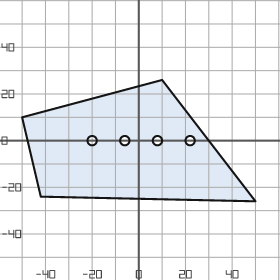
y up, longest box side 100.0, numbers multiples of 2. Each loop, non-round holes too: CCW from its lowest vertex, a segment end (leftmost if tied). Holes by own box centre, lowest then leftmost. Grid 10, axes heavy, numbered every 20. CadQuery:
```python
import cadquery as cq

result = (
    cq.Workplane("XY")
    .moveTo(50.0, -26.0)
    .lineTo(10.0, 26.0)
    .lineTo(-50.0, 10.0)
    .lineTo(-42.0, -24.0)
    .close()
    .moveTo(-20.0, 0.0)
    .circle(2.0)
    .moveTo(-6.0, 0.0)
    .circle(2.0)
    .moveTo(8.0, 0.0)
    .circle(2.0)
    .moveTo(22.0, 0.0)
    .circle(2.0)
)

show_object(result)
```